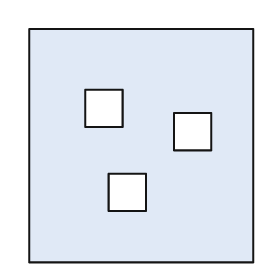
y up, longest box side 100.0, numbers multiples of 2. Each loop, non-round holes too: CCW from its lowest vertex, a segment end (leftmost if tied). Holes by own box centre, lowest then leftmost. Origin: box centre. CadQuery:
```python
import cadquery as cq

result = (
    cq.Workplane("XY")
    .moveTo(-48.0, -50.0)
    .lineTo(48.0, -50.0)
    .lineTo(48.0, 50.0)
    .lineTo(-48.0, 50.0)
    .close()
    .moveTo(-14.0, -28.0)
    .lineTo(2.0, -28.0)
    .lineTo(2.0, -12.0)
    .lineTo(-14.0, -12.0)
    .close()
    .moveTo(14.0, -2.0)
    .lineTo(30.0, -2.0)
    .lineTo(30.0, 14.0)
    .lineTo(14.0, 14.0)
    .close()
    .moveTo(-24.0, 8.0)
    .lineTo(-8.0, 8.0)
    .lineTo(-8.0, 24.0)
    .lineTo(-24.0, 24.0)
    .close()
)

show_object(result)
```